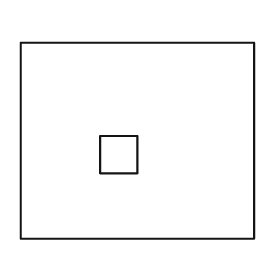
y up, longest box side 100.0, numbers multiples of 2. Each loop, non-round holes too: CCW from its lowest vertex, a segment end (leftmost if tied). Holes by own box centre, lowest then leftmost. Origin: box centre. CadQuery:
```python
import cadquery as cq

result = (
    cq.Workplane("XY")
    .moveTo(-50.0, -42.0)
    .lineTo(50.0, -42.0)
    .lineTo(50.0, 42.0)
    .lineTo(-50.0, 42.0)
    .close()
    .moveTo(-16.0, -14.0)
    .lineTo(0.0, -14.0)
    .lineTo(0.0, 2.0)
    .lineTo(-16.0, 2.0)
    .close()
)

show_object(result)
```